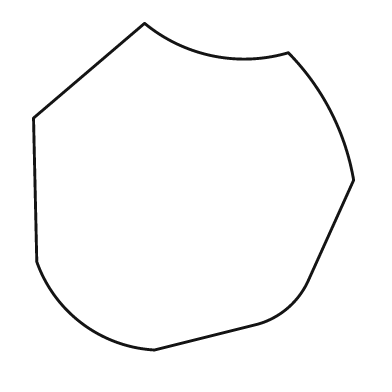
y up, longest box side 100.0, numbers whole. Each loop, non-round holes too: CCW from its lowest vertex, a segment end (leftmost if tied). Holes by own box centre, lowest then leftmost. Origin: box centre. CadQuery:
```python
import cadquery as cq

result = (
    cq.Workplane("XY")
    .moveTo(-12.0, -50.0)
    .lineTo(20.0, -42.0)
    .threePointArc((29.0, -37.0), (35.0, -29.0))
    .lineTo(49.0, 2.0)
    .threePointArc((42.0, 23.0), (29.0, 41.0))
    .threePointArc((6.0, 40.0), (-15.0, 50.0))
    .lineTo(-49.0, 21.0)
    .lineTo(-48.0, -23.0)
    .threePointArc((-34.0, -42.0), (-12.0, -50.0))
    .close()
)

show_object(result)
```